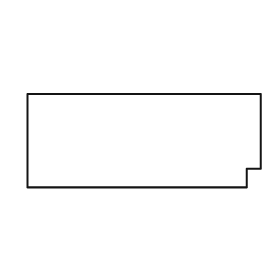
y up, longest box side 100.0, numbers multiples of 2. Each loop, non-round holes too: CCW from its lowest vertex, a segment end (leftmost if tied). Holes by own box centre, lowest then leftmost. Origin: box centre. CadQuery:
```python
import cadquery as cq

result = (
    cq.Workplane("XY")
    .moveTo(-50.0, -20.0)
    .lineTo(44.0, -20.0)
    .lineTo(44.0, -12.0)
    .lineTo(50.0, -12.0)
    .lineTo(50.0, 20.0)
    .lineTo(-50.0, 20.0)
    .close()
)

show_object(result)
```